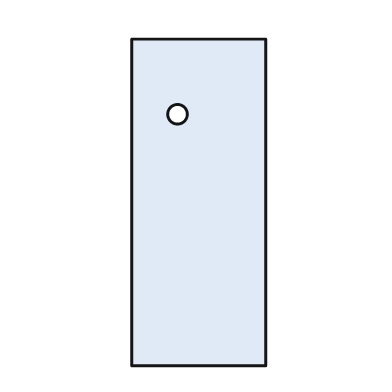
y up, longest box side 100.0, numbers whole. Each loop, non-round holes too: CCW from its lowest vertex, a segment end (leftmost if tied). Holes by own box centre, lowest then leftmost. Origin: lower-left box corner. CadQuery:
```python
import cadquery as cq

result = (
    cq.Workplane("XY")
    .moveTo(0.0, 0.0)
    .lineTo(41.0, 0.0)
    .lineTo(41.0, 100.0)
    .lineTo(0.0, 100.0)
    .close()
    .moveTo(14.0, 77.0)
    .circle(3.0)
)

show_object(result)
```